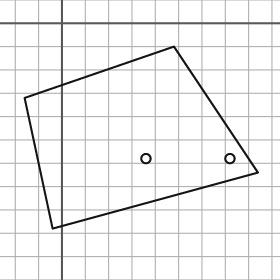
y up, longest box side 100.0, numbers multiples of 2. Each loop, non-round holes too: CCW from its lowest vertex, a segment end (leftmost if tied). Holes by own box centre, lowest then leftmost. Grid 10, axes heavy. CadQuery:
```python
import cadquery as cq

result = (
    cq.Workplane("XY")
    .moveTo(-4.0, -88.0)
    .lineTo(84.0, -64.0)
    .lineTo(48.0, -10.0)
    .lineTo(-16.0, -32.0)
    .close()
    .moveTo(36.0, -58.0)
    .circle(2.0)
    .moveTo(72.0, -58.0)
    .circle(2.0)
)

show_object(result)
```